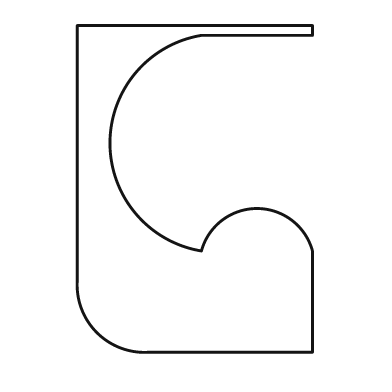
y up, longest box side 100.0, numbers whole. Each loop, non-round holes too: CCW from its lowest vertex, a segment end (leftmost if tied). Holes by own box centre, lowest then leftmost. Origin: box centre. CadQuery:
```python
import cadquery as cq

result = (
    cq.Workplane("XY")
    .moveTo(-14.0, -50.0)
    .lineTo(36.0, -50.0)
    .lineTo(36.0, -19.0)
    .threePointArc((19.0, -6.0), (2.0, -19.0))
    .threePointArc((-26.0, 14.0), (2.0, 47.0))
    .lineTo(36.0, 47.0)
    .lineTo(36.0, 50.0)
    .lineTo(-36.0, 50.0)
    .lineTo(-36.0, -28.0)
    .threePointArc((-30.0, -44.0), (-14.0, -50.0))
    .close()
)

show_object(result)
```